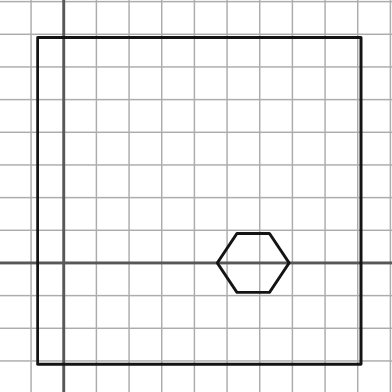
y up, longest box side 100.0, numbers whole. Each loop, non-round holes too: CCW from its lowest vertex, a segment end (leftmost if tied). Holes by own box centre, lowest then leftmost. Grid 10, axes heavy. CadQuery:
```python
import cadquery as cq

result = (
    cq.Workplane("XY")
    .moveTo(-8.0, -31.0)
    .lineTo(91.0, -31.0)
    .lineTo(91.0, 69.0)
    .lineTo(-8.0, 69.0)
    .close()
    .moveTo(53.0, -9.0)
    .lineTo(63.0, -9.0)
    .lineTo(69.0, 0.0)
    .lineTo(63.0, 9.0)
    .lineTo(53.0, 9.0)
    .lineTo(47.0, 0.0)
    .close()
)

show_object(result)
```